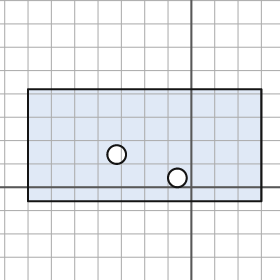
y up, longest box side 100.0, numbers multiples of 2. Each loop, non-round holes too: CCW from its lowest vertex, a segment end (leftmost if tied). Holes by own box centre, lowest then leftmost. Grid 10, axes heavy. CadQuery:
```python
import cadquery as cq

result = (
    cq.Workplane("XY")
    .moveTo(-70.0, -6.0)
    .lineTo(30.0, -6.0)
    .lineTo(30.0, 42.0)
    .lineTo(-70.0, 42.0)
    .close()
    .moveTo(-6.0, 4.0)
    .circle(4.0)
    .moveTo(-32.0, 14.0)
    .circle(4.0)
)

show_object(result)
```